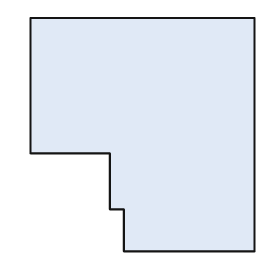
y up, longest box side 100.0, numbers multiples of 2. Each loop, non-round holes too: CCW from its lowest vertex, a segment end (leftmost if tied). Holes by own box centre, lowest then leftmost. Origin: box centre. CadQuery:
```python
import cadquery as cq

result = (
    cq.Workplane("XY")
    .moveTo(-8.0, -50.0)
    .lineTo(48.0, -50.0)
    .lineTo(48.0, 50.0)
    .lineTo(-48.0, 50.0)
    .lineTo(-48.0, -8.0)
    .lineTo(-14.0, -8.0)
    .lineTo(-14.0, -32.0)
    .lineTo(-8.0, -32.0)
    .close()
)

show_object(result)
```